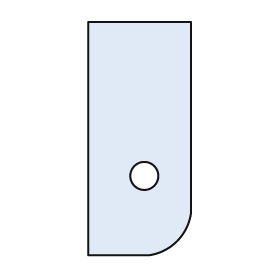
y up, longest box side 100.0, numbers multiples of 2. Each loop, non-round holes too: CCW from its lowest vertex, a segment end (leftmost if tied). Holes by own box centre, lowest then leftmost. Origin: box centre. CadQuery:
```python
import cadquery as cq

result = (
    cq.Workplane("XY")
    .moveTo(-22.0, -50.0)
    .lineTo(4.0, -50.0)
    .threePointArc((16.0, -44.0), (22.0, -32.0))
    .lineTo(22.0, 50.0)
    .lineTo(-22.0, 50.0)
    .close()
    .moveTo(2.0, -16.0)
    .circle(6.0)
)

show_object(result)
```